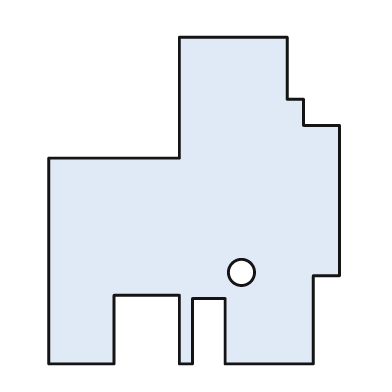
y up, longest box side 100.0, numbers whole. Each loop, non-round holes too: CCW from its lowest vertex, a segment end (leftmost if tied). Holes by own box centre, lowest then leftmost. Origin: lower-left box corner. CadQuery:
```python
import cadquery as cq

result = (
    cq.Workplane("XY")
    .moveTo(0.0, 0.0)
    .lineTo(20.0, 0.0)
    .lineTo(20.0, 21.0)
    .lineTo(40.0, 21.0)
    .lineTo(40.0, 0.0)
    .lineTo(44.0, 0.0)
    .lineTo(44.0, 20.0)
    .lineTo(54.0, 20.0)
    .lineTo(54.0, 0.0)
    .lineTo(81.0, 0.0)
    .lineTo(81.0, 27.0)
    .lineTo(89.0, 27.0)
    .lineTo(89.0, 73.0)
    .lineTo(78.0, 73.0)
    .lineTo(78.0, 81.0)
    .lineTo(73.0, 81.0)
    .lineTo(73.0, 100.0)
    .lineTo(40.0, 100.0)
    .lineTo(40.0, 63.0)
    .lineTo(0.0, 63.0)
    .close()
    .moveTo(59.0, 28.0)
    .circle(4.0)
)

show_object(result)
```